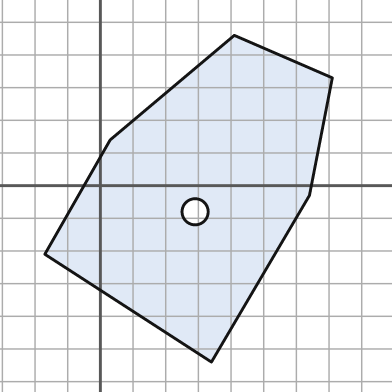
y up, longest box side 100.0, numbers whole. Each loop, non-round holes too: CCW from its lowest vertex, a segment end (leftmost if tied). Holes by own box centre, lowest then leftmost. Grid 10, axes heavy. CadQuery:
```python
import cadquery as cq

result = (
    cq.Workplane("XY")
    .moveTo(34.0, -54.0)
    .lineTo(64.0, -3.0)
    .lineTo(71.0, 33.0)
    .lineTo(41.0, 46.0)
    .lineTo(3.0, 14.0)
    .lineTo(-17.0, -21.0)
    .close()
    .moveTo(29.0, -8.0)
    .circle(4.0)
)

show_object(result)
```